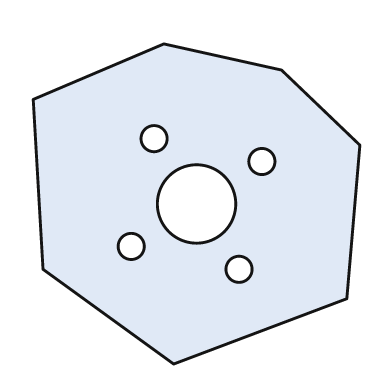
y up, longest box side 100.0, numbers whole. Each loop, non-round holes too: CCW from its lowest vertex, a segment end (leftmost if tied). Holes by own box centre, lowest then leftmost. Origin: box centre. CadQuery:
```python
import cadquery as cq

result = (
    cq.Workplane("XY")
    .moveTo(-7.0, -49.0)
    .lineTo(46.0, -29.0)
    .lineTo(50.0, 18.0)
    .lineTo(26.0, 41.0)
    .lineTo(-10.0, 49.0)
    .lineTo(-50.0, 32.0)
    .lineTo(-47.0, -20.0)
    .close()
    .moveTo(13.0, -20.0)
    .circle(4.0)
    .moveTo(-20.0, -13.0)
    .circle(4.0)
    .moveTo(0.0, 0.0)
    .circle(12.0)
    .moveTo(20.0, 13.0)
    .circle(4.0)
    .moveTo(-13.0, 20.0)
    .circle(4.0)
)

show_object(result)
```